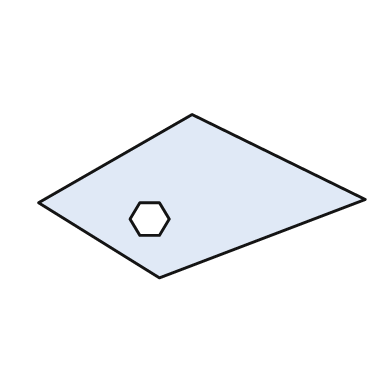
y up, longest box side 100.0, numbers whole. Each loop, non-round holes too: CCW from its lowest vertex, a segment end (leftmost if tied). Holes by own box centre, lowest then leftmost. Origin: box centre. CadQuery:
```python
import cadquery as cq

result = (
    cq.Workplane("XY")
    .moveTo(-13.0, -25.0)
    .lineTo(50.0, -1.0)
    .lineTo(-3.0, 25.0)
    .lineTo(-50.0, -2.0)
    .close()
    .moveTo(-19.0, -12.0)
    .lineTo(-13.0, -12.0)
    .lineTo(-10.0, -7.0)
    .lineTo(-13.0, -2.0)
    .lineTo(-19.0, -2.0)
    .lineTo(-22.0, -7.0)
    .close()
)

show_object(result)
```